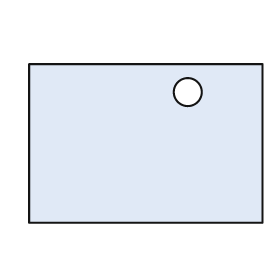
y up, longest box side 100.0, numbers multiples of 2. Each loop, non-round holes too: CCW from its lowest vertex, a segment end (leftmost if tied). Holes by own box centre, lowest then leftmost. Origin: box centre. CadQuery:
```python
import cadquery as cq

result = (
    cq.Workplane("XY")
    .moveTo(-50.0, -34.0)
    .lineTo(50.0, -34.0)
    .lineTo(50.0, 34.0)
    .lineTo(-50.0, 34.0)
    .close()
    .moveTo(18.0, 22.0)
    .circle(6.0)
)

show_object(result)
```